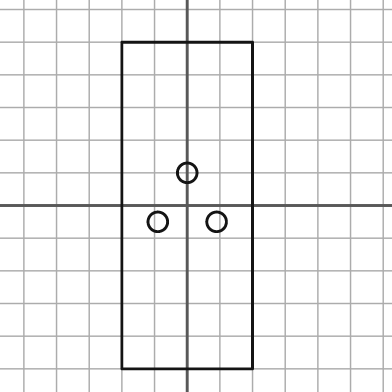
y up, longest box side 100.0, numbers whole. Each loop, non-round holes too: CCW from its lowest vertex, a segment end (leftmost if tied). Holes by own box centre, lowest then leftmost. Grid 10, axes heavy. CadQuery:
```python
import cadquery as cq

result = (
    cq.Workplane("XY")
    .moveTo(-20.0, -50.0)
    .lineTo(20.0, -50.0)
    .lineTo(20.0, 50.0)
    .lineTo(-20.0, 50.0)
    .close()
    .moveTo(-9.0, -5.0)
    .circle(3.0)
    .moveTo(9.0, -5.0)
    .circle(3.0)
    .moveTo(0.0, 10.0)
    .circle(3.0)
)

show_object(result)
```